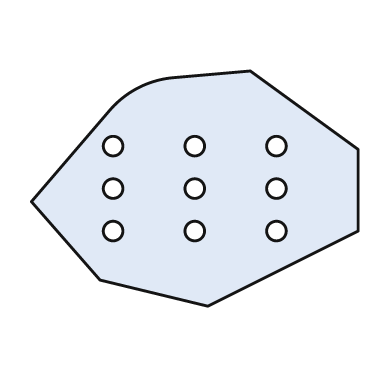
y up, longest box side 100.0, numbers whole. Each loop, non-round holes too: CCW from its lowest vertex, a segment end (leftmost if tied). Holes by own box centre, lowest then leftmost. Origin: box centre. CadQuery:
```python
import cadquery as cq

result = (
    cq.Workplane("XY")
    .moveTo(4.0, -36.0)
    .lineTo(50.0, -13.0)
    .lineTo(50.0, 12.0)
    .lineTo(17.0, 36.0)
    .lineTo(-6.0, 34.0)
    .threePointArc((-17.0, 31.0), (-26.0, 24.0))
    .lineTo(-50.0, -4.0)
    .lineTo(-29.0, -28.0)
    .close()
    .moveTo(-25.0, -13.0)
    .circle(3.0)
    .moveTo(0.0, -13.0)
    .circle(3.0)
    .moveTo(25.0, -13.0)
    .circle(3.0)
    .moveTo(-25.0, 0.0)
    .circle(3.0)
    .moveTo(0.0, 0.0)
    .circle(3.0)
    .moveTo(25.0, 0.0)
    .circle(3.0)
    .moveTo(-25.0, 13.0)
    .circle(3.0)
    .moveTo(0.0, 13.0)
    .circle(3.0)
    .moveTo(25.0, 13.0)
    .circle(3.0)
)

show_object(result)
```